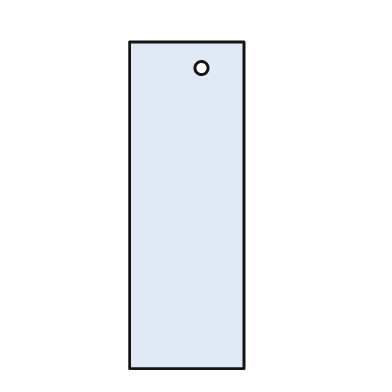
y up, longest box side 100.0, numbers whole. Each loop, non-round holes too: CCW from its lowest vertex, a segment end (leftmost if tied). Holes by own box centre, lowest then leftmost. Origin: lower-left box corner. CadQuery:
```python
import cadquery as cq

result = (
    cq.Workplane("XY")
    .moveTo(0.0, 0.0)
    .lineTo(35.0, 0.0)
    .lineTo(35.0, 100.0)
    .lineTo(0.0, 100.0)
    .close()
    .moveTo(22.0, 92.0)
    .circle(2.0)
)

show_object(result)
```